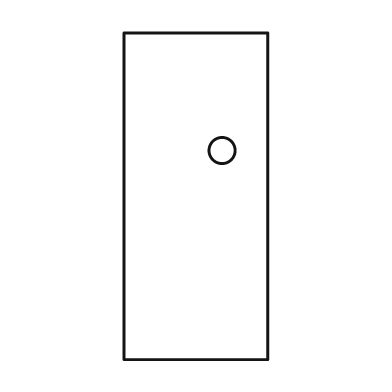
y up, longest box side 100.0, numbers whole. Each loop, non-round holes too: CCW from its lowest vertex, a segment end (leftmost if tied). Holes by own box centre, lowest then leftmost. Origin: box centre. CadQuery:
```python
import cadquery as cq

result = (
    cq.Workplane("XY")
    .moveTo(-22.0, -50.0)
    .lineTo(22.0, -50.0)
    .lineTo(22.0, 50.0)
    .lineTo(-22.0, 50.0)
    .close()
    .moveTo(8.0, 14.0)
    .circle(4.0)
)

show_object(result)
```